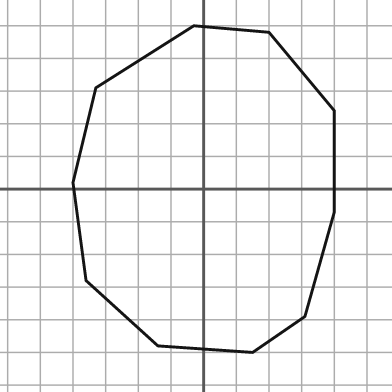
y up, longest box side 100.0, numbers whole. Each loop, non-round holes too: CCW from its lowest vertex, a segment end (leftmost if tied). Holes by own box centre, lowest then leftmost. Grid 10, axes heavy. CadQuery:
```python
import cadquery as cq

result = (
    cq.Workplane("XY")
    .moveTo(15.0, -50.0)
    .lineTo(31.0, -39.0)
    .lineTo(40.0, -7.0)
    .lineTo(40.0, 24.0)
    .lineTo(20.0, 48.0)
    .lineTo(-3.0, 50.0)
    .lineTo(-33.0, 31.0)
    .lineTo(-40.0, 2.0)
    .lineTo(-36.0, -28.0)
    .lineTo(-14.0, -48.0)
    .close()
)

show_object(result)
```